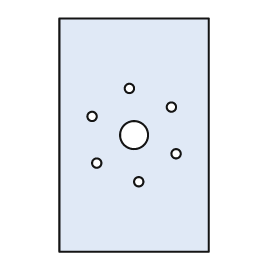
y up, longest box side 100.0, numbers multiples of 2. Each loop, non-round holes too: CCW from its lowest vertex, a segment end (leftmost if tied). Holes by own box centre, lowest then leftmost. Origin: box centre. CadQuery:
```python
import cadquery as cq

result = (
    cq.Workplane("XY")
    .moveTo(-32.0, -50.0)
    .lineTo(32.0, -50.0)
    .lineTo(32.0, 50.0)
    .lineTo(-32.0, 50.0)
    .close()
    .moveTo(2.0, -20.0)
    .circle(2.0)
    .moveTo(-16.0, -12.0)
    .circle(2.0)
    .moveTo(18.0, -8.0)
    .circle(2.0)
    .moveTo(0.0, 0.0)
    .circle(6.0)
    .moveTo(-18.0, 8.0)
    .circle(2.0)
    .moveTo(16.0, 12.0)
    .circle(2.0)
    .moveTo(-2.0, 20.0)
    .circle(2.0)
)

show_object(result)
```